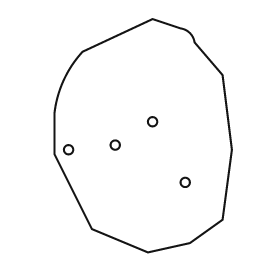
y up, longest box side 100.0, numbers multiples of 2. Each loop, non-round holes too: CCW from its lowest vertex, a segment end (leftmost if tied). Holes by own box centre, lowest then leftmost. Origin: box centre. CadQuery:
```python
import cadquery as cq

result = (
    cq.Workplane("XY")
    .moveTo(2.0, -50.0)
    .lineTo(20.0, -46.0)
    .lineTo(34.0, -36.0)
    .lineTo(38.0, -6.0)
    .lineTo(34.0, 26.0)
    .lineTo(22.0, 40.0)
    .threePointArc((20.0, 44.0), (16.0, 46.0))
    .lineTo(4.0, 50.0)
    .lineTo(-26.0, 36.0)
    .threePointArc((-34.0, 24.0), (-38.0, 10.0))
    .lineTo(-38.0, -8.0)
    .lineTo(-22.0, -40.0)
    .close()
    .moveTo(18.0, -20.0)
    .circle(2.0)
    .moveTo(-32.0, -6.0)
    .circle(2.0)
    .moveTo(-12.0, -4.0)
    .circle(2.0)
    .moveTo(4.0, 6.0)
    .circle(2.0)
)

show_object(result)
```